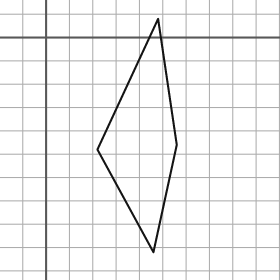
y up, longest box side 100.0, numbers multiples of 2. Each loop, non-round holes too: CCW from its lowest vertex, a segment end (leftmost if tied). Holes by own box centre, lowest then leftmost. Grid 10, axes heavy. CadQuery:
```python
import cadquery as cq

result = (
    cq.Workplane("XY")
    .moveTo(46.0, -92.0)
    .lineTo(56.0, -46.0)
    .lineTo(48.0, 8.0)
    .lineTo(22.0, -48.0)
    .close()
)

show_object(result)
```